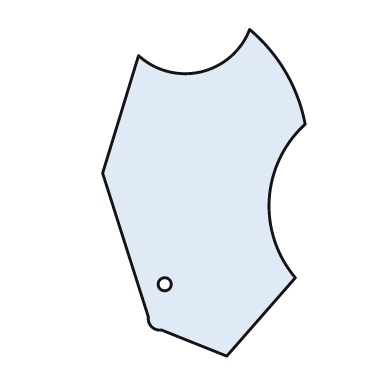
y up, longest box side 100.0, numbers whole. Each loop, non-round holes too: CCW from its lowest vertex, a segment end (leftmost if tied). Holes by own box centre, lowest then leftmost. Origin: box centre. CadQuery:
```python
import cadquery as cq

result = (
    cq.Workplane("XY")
    .moveTo(7.0, -50.0)
    .lineTo(28.0, -26.0)
    .threePointArc((20.0, -2.0), (31.0, 21.0))
    .threePointArc((25.0, 37.0), (14.0, 50.0))
    .threePointArc((-1.0, 37.0), (-20.0, 42.0))
    .lineTo(-31.0, 6.0)
    .lineTo(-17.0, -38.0)
    .threePointArc((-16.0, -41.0), (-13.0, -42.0))
    .close()
    .moveTo(-12.0, -28.0)
    .circle(2.0)
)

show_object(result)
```